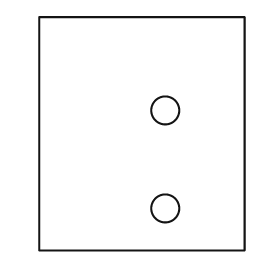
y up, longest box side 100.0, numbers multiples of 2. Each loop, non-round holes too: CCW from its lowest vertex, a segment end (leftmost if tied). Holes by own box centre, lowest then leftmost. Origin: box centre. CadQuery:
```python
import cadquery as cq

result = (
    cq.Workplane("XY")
    .moveTo(-44.0, -50.0)
    .lineTo(44.0, -50.0)
    .lineTo(44.0, 50.0)
    .lineTo(-44.0, 50.0)
    .close()
    .moveTo(10.0, -32.0)
    .circle(6.0)
    .moveTo(10.0, 10.0)
    .circle(6.0)
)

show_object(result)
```